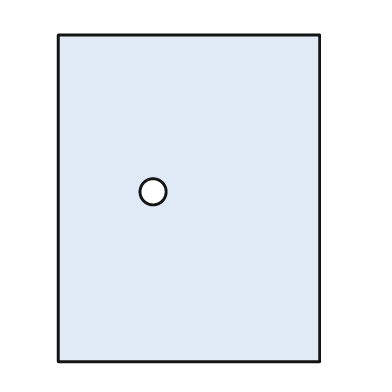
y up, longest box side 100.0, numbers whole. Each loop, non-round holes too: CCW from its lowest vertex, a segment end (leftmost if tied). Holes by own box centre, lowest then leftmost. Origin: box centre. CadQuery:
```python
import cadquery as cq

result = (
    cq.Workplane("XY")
    .moveTo(-40.0, -50.0)
    .lineTo(40.0, -50.0)
    .lineTo(40.0, 50.0)
    .lineTo(-40.0, 50.0)
    .close()
    .moveTo(-11.0, 2.0)
    .circle(4.0)
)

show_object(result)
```